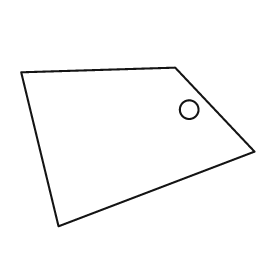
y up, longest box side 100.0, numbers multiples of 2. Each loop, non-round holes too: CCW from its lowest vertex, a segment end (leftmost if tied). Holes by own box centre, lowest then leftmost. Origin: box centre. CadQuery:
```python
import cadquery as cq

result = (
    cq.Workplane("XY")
    .moveTo(-34.0, -34.0)
    .lineTo(50.0, -2.0)
    .lineTo(16.0, 34.0)
    .lineTo(-50.0, 32.0)
    .close()
    .moveTo(22.0, 16.0)
    .circle(4.0)
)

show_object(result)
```